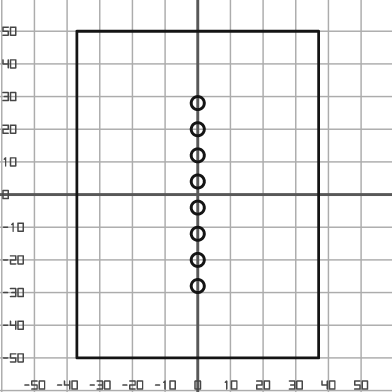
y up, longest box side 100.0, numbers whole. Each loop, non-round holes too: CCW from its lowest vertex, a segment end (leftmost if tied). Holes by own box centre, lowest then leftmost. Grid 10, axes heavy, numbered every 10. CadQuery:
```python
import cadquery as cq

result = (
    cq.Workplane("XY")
    .moveTo(-37.0, -50.0)
    .lineTo(37.0, -50.0)
    .lineTo(37.0, 50.0)
    .lineTo(-37.0, 50.0)
    .close()
    .moveTo(0.0, -28.0)
    .circle(2.0)
    .moveTo(0.0, -20.0)
    .circle(2.0)
    .moveTo(0.0, -12.0)
    .circle(2.0)
    .moveTo(0.0, -4.0)
    .circle(2.0)
    .moveTo(0.0, 4.0)
    .circle(2.0)
    .moveTo(0.0, 12.0)
    .circle(2.0)
    .moveTo(0.0, 20.0)
    .circle(2.0)
    .moveTo(0.0, 28.0)
    .circle(2.0)
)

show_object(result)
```